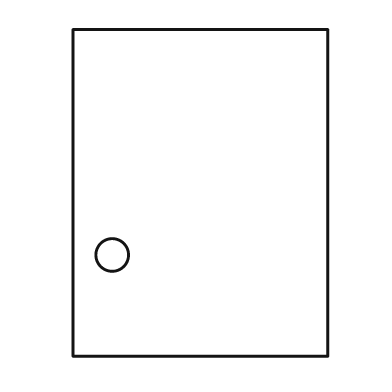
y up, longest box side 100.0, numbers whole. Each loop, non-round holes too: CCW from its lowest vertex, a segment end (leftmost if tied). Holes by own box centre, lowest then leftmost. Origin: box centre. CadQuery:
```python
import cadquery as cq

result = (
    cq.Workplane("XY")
    .moveTo(-39.0, -50.0)
    .lineTo(39.0, -50.0)
    .lineTo(39.0, 50.0)
    .lineTo(-39.0, 50.0)
    .close()
    .moveTo(-27.0, -19.0)
    .circle(5.0)
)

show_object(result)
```